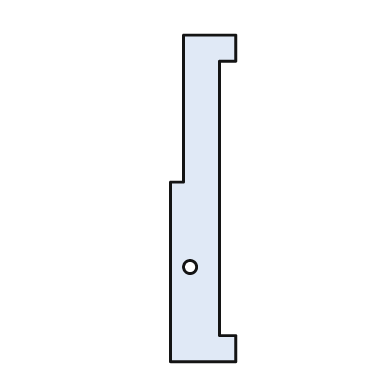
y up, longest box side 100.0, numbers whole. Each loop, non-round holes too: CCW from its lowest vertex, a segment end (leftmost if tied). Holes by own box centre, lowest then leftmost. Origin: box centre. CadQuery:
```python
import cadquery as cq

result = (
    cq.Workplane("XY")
    .moveTo(-10.0, -50.0)
    .lineTo(10.0, -50.0)
    .lineTo(10.0, -42.0)
    .lineTo(5.0, -42.0)
    .lineTo(5.0, 42.0)
    .lineTo(10.0, 42.0)
    .lineTo(10.0, 50.0)
    .lineTo(-6.0, 50.0)
    .lineTo(-6.0, 5.0)
    .lineTo(-10.0, 5.0)
    .close()
    .moveTo(-4.0, -21.0)
    .circle(2.0)
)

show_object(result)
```